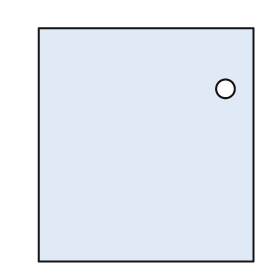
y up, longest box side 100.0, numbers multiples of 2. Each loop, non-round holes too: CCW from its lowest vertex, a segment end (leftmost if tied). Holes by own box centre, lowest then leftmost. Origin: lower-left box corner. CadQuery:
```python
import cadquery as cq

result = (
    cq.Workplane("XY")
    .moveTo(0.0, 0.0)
    .lineTo(92.0, 0.0)
    .lineTo(92.0, 100.0)
    .lineTo(0.0, 100.0)
    .close()
    .moveTo(80.0, 74.0)
    .circle(4.0)
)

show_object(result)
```